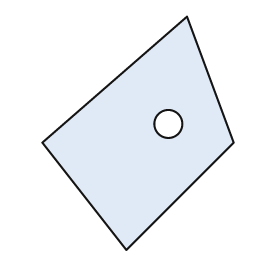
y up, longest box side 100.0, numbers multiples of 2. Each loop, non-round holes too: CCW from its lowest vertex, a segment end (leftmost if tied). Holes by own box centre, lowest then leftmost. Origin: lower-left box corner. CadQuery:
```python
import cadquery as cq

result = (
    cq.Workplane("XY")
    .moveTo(36.0, 0.0)
    .lineTo(82.0, 46.0)
    .lineTo(62.0, 100.0)
    .lineTo(0.0, 46.0)
    .close()
    .moveTo(54.0, 54.0)
    .circle(6.0)
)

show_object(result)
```